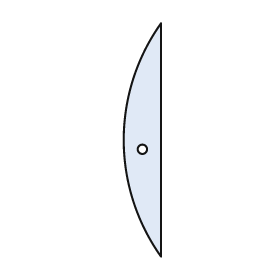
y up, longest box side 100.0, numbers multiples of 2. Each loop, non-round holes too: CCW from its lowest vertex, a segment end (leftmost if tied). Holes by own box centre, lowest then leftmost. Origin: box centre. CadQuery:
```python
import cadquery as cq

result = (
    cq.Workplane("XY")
    .moveTo(8.0, -50.0)
    .lineTo(8.0, 50.0)
    .threePointArc((-8.0, 0.0), (8.0, -50.0))
    .close()
    .moveTo(0.0, -4.0)
    .circle(2.0)
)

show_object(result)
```